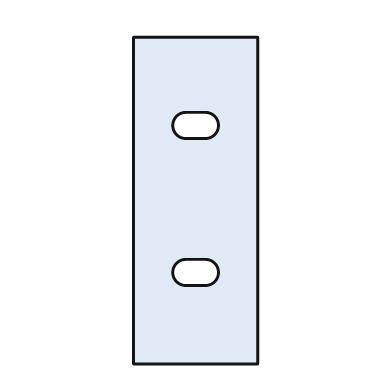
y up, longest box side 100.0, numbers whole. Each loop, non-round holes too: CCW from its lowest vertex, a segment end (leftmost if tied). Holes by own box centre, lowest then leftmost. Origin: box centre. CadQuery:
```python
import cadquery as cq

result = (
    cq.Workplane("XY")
    .moveTo(-19.0, -50.0)
    .lineTo(19.0, -50.0)
    .lineTo(19.0, 50.0)
    .lineTo(-19.0, 50.0)
    .close()
    .moveTo(-3.0, -26.0)
    .lineTo(3.0, -26.0)
    .threePointArc((7.0, -22.0), (3.0, -18.0))
    .lineTo(-3.0, -18.0)
    .threePointArc((-7.0, -22.0), (-3.0, -26.0))
    .close()
    .moveTo(-3.0, 19.0)
    .lineTo(3.0, 19.0)
    .threePointArc((7.0, 23.0), (3.0, 27.0))
    .lineTo(-3.0, 27.0)
    .threePointArc((-7.0, 23.0), (-3.0, 19.0))
    .close()
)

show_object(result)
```